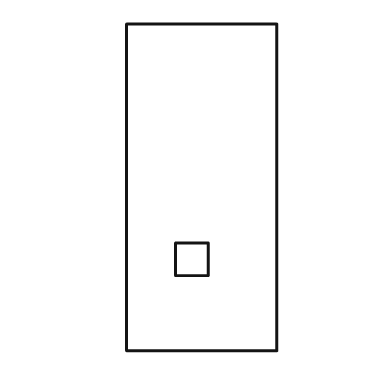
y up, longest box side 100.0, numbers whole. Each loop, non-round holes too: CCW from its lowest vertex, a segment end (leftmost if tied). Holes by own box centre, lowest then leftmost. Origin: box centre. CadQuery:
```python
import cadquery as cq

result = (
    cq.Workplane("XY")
    .moveTo(-23.0, -50.0)
    .lineTo(23.0, -50.0)
    .lineTo(23.0, 50.0)
    .lineTo(-23.0, 50.0)
    .close()
    .moveTo(-8.0, -27.0)
    .lineTo(2.0, -27.0)
    .lineTo(2.0, -17.0)
    .lineTo(-8.0, -17.0)
    .close()
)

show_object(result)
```